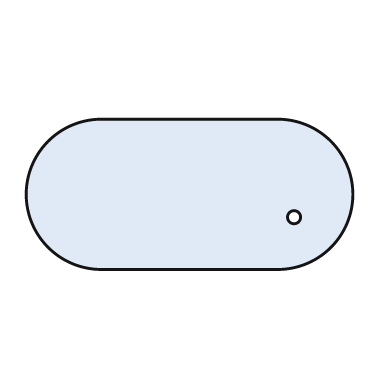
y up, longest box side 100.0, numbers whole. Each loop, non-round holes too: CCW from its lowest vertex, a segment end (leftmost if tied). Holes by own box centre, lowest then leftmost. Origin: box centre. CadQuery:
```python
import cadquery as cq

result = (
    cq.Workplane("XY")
    .moveTo(-27.0, -23.0)
    .lineTo(27.0, -23.0)
    .threePointArc((50.0, 0.0), (27.0, 23.0))
    .lineTo(-27.0, 23.0)
    .threePointArc((-50.0, 0.0), (-27.0, -23.0))
    .close()
    .moveTo(32.0, -7.0)
    .circle(2.0)
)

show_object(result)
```